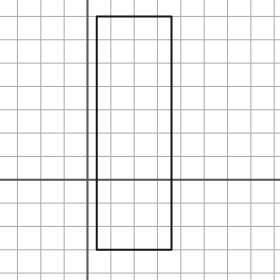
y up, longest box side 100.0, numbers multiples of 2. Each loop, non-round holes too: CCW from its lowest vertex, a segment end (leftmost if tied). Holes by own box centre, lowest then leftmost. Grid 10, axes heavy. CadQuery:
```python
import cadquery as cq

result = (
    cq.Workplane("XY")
    .moveTo(4.0, -30.0)
    .lineTo(36.0, -30.0)
    .lineTo(36.0, 70.0)
    .lineTo(4.0, 70.0)
    .close()
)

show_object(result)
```